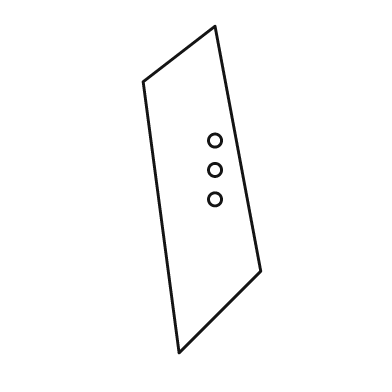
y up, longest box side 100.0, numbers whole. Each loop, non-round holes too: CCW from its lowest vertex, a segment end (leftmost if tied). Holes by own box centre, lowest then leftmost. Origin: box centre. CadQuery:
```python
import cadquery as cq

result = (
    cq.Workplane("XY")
    .moveTo(-7.0, -50.0)
    .lineTo(18.0, -25.0)
    .lineTo(4.0, 50.0)
    .lineTo(-18.0, 33.0)
    .close()
    .moveTo(4.0, -3.0)
    .circle(2.0)
    .moveTo(4.0, 6.0)
    .circle(2.0)
    .moveTo(4.0, 15.0)
    .circle(2.0)
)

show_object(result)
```